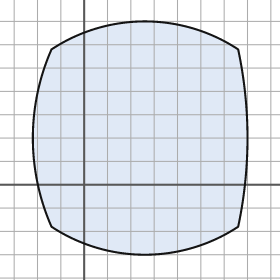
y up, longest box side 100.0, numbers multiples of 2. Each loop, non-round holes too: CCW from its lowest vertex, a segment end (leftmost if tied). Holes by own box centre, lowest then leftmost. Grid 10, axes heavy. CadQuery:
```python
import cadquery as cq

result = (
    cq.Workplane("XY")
    .moveTo(-14.0, -18.0)
    .threePointArc((26.0, -30.0), (66.0, -18.0))
    .threePointArc((70.0, 20.0), (66.0, 58.0))
    .threePointArc((26.0, 70.0), (-14.0, 58.0))
    .threePointArc((-22.0, 20.0), (-14.0, -18.0))
    .close()
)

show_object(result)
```